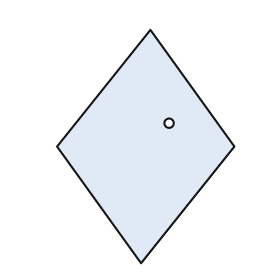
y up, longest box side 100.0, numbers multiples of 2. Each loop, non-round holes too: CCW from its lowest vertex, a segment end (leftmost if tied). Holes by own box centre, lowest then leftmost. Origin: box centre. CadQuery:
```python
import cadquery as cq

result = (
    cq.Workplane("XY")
    .moveTo(-2.0, -50.0)
    .lineTo(38.0, 0.0)
    .lineTo(2.0, 50.0)
    .lineTo(-38.0, 0.0)
    .close()
    .moveTo(10.0, 10.0)
    .circle(2.0)
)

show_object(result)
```